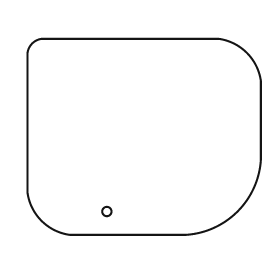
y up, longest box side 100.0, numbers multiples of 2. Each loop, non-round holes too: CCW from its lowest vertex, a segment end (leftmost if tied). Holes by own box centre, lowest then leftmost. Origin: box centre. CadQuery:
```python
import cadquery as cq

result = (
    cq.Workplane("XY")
    .moveTo(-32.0, -42.0)
    .lineTo(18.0, -42.0)
    .threePointArc((40.0, -32.0), (50.0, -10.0))
    .lineTo(50.0, 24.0)
    .threePointArc((44.0, 36.0), (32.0, 42.0))
    .lineTo(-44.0, 42.0)
    .threePointArc((-48.0, 40.0), (-50.0, 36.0))
    .lineTo(-50.0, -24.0)
    .threePointArc((-44.0, -36.0), (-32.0, -42.0))
    .close()
    .moveTo(-16.0, -32.0)
    .circle(2.0)
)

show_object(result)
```